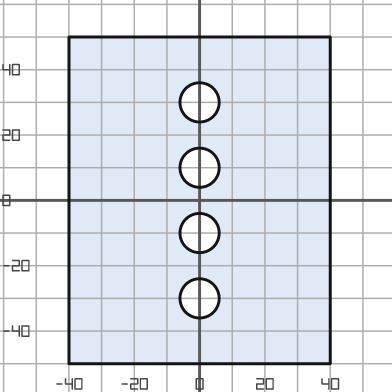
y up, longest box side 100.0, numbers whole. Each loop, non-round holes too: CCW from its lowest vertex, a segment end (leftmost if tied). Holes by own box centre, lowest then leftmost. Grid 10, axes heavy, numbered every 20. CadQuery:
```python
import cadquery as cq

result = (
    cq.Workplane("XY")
    .moveTo(-40.0, -50.0)
    .lineTo(40.0, -50.0)
    .lineTo(40.0, 50.0)
    .lineTo(-40.0, 50.0)
    .close()
    .moveTo(0.0, -30.0)
    .circle(6.0)
    .moveTo(0.0, -10.0)
    .circle(6.0)
    .moveTo(0.0, 10.0)
    .circle(6.0)
    .moveTo(0.0, 30.0)
    .circle(6.0)
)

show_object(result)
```